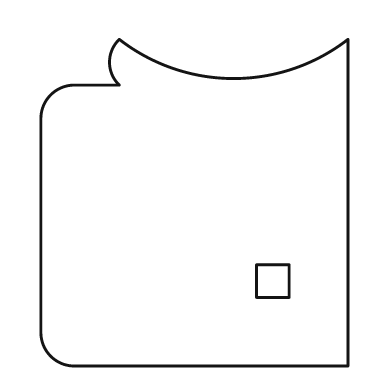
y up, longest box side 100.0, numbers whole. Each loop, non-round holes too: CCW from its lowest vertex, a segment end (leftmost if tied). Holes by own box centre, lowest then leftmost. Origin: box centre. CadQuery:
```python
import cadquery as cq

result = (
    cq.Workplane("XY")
    .moveTo(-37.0, -50.0)
    .lineTo(47.0, -50.0)
    .lineTo(47.0, 50.0)
    .threePointArc((12.0, 38.0), (-23.0, 50.0))
    .threePointArc((-26.0, 43.0), (-23.0, 36.0))
    .lineTo(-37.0, 36.0)
    .threePointArc((-44.0, 33.0), (-47.0, 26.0))
    .lineTo(-47.0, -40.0)
    .threePointArc((-44.0, -47.0), (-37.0, -50.0))
    .close()
    .moveTo(19.0, -29.0)
    .lineTo(29.0, -29.0)
    .lineTo(29.0, -19.0)
    .lineTo(19.0, -19.0)
    .close()
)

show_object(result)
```